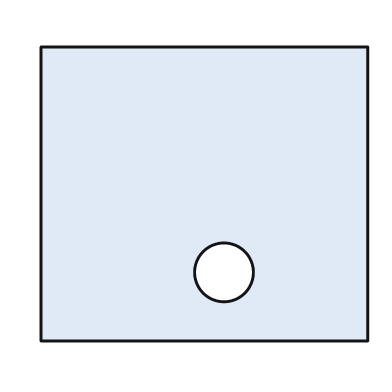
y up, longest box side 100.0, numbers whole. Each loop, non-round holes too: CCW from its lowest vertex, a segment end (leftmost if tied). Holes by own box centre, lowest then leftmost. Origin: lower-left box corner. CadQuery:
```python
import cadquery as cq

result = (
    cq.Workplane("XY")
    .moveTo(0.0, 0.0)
    .lineTo(100.0, 0.0)
    .lineTo(100.0, 90.0)
    .lineTo(0.0, 90.0)
    .close()
    .moveTo(56.0, 21.0)
    .circle(9.0)
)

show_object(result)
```